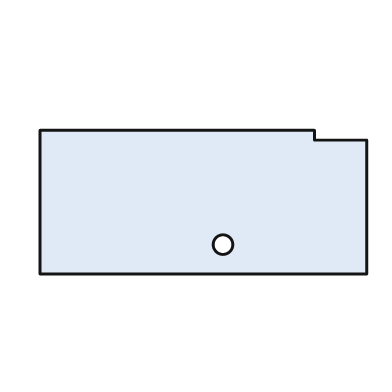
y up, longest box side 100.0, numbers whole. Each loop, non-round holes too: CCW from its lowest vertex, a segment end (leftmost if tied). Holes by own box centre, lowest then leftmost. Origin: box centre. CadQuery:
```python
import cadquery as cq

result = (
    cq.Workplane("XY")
    .moveTo(-50.0, -22.0)
    .lineTo(50.0, -22.0)
    .lineTo(50.0, 19.0)
    .lineTo(34.0, 19.0)
    .lineTo(34.0, 22.0)
    .lineTo(-50.0, 22.0)
    .close()
    .moveTo(6.0, -13.0)
    .circle(3.0)
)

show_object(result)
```